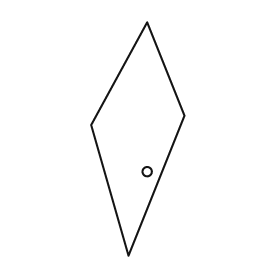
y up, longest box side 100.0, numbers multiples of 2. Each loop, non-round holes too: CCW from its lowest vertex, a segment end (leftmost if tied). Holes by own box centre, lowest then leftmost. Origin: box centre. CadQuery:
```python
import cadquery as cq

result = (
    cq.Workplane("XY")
    .moveTo(-4.0, -50.0)
    .lineTo(20.0, 10.0)
    .lineTo(4.0, 50.0)
    .lineTo(-20.0, 6.0)
    .close()
    .moveTo(4.0, -14.0)
    .circle(2.0)
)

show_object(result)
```